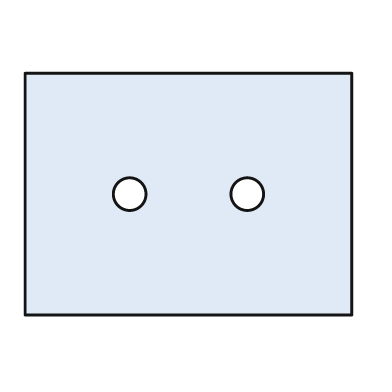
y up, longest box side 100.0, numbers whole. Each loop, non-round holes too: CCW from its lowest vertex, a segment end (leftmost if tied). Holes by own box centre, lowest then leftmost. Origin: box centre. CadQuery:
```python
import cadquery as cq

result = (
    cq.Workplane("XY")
    .moveTo(-50.0, -37.0)
    .lineTo(50.0, -37.0)
    .lineTo(50.0, 37.0)
    .lineTo(-50.0, 37.0)
    .close()
    .moveTo(-18.0, 0.0)
    .circle(5.0)
    .moveTo(18.0, 0.0)
    .circle(5.0)
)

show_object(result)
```